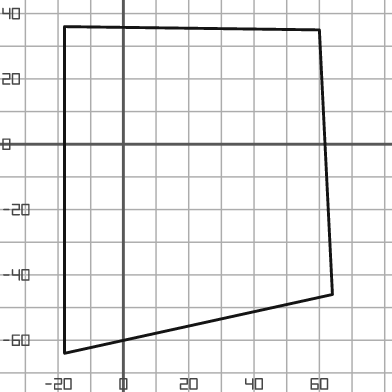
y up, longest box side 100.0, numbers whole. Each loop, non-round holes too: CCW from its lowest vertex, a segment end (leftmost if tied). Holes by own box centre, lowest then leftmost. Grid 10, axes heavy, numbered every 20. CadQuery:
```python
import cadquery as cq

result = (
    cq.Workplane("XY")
    .moveTo(-18.0, -64.0)
    .lineTo(64.0, -46.0)
    .lineTo(60.0, 35.0)
    .lineTo(-18.0, 36.0)
    .close()
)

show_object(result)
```